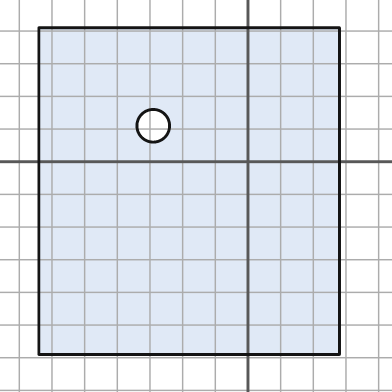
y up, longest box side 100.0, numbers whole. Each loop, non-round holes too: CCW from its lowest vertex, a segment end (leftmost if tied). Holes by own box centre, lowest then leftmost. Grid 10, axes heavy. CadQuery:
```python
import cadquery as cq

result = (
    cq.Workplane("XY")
    .moveTo(-64.0, -59.0)
    .lineTo(28.0, -59.0)
    .lineTo(28.0, 41.0)
    .lineTo(-64.0, 41.0)
    .close()
    .moveTo(-29.0, 11.0)
    .circle(5.0)
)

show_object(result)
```